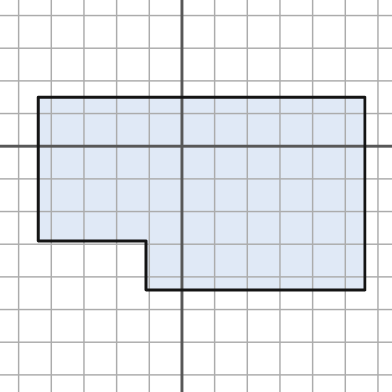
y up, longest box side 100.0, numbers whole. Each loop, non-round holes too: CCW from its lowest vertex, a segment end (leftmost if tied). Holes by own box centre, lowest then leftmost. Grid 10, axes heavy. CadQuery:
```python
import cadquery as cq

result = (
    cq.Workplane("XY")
    .moveTo(-11.0, -44.0)
    .lineTo(56.0, -44.0)
    .lineTo(56.0, 15.0)
    .lineTo(-44.0, 15.0)
    .lineTo(-44.0, -29.0)
    .lineTo(-11.0, -29.0)
    .close()
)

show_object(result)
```